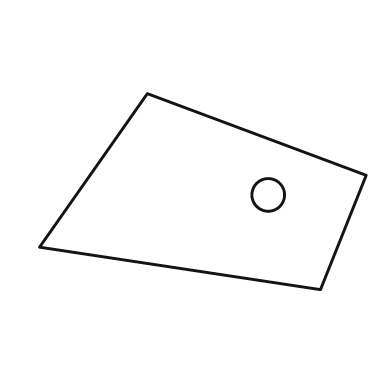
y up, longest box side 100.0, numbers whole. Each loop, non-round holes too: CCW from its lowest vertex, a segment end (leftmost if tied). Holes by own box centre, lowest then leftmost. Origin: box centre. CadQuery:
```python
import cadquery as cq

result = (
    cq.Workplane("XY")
    .moveTo(36.0, -30.0)
    .lineTo(50.0, 5.0)
    .lineTo(-17.0, 30.0)
    .lineTo(-50.0, -17.0)
    .close()
    .moveTo(20.0, -1.0)
    .circle(5.0)
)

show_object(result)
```